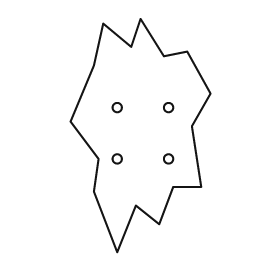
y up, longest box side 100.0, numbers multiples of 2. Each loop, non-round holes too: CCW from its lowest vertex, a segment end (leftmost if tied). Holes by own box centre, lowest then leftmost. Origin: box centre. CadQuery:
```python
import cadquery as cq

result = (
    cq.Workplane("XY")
    .moveTo(-10.0, -50.0)
    .lineTo(-2.0, -30.0)
    .lineTo(8.0, -38.0)
    .lineTo(14.0, -22.0)
    .lineTo(26.0, -22.0)
    .lineTo(22.0, 4.0)
    .lineTo(30.0, 18.0)
    .lineTo(20.0, 36.0)
    .lineTo(10.0, 34.0)
    .lineTo(0.0, 50.0)
    .lineTo(-4.0, 38.0)
    .lineTo(-16.0, 48.0)
    .lineTo(-20.0, 30.0)
    .lineTo(-30.0, 6.0)
    .lineTo(-18.0, -10.0)
    .lineTo(-20.0, -24.0)
    .close()
    .moveTo(-10.0, -10.0)
    .circle(2.0)
    .moveTo(12.0, -10.0)
    .circle(2.0)
    .moveTo(-10.0, 12.0)
    .circle(2.0)
    .moveTo(12.0, 12.0)
    .circle(2.0)
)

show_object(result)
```